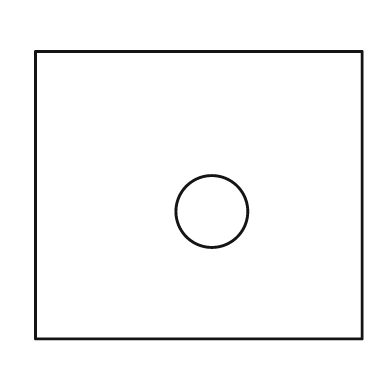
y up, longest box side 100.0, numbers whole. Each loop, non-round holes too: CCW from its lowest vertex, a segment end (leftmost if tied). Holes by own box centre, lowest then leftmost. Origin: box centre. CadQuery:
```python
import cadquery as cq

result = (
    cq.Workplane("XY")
    .moveTo(-50.0, -44.0)
    .lineTo(50.0, -44.0)
    .lineTo(50.0, 44.0)
    .lineTo(-50.0, 44.0)
    .close()
    .moveTo(4.0, -5.0)
    .circle(11.0)
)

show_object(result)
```